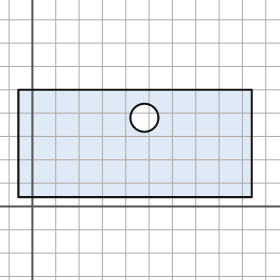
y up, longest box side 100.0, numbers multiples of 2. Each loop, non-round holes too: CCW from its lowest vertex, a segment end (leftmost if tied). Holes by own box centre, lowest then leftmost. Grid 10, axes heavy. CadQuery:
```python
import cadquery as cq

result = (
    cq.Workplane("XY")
    .moveTo(-6.0, 4.0)
    .lineTo(94.0, 4.0)
    .lineTo(94.0, 50.0)
    .lineTo(-6.0, 50.0)
    .close()
    .moveTo(48.0, 38.0)
    .circle(6.0)
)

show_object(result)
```